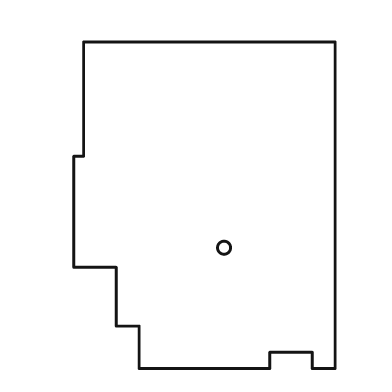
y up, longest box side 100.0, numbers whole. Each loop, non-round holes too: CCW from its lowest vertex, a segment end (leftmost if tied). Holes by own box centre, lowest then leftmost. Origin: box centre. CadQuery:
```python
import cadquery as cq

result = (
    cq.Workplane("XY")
    .moveTo(-20.0, -50.0)
    .lineTo(20.0, -50.0)
    .lineTo(20.0, -45.0)
    .lineTo(33.0, -45.0)
    .lineTo(33.0, -50.0)
    .lineTo(40.0, -50.0)
    .lineTo(40.0, 50.0)
    .lineTo(-37.0, 50.0)
    .lineTo(-37.0, 15.0)
    .lineTo(-40.0, 15.0)
    .lineTo(-40.0, -19.0)
    .lineTo(-27.0, -19.0)
    .lineTo(-27.0, -37.0)
    .lineTo(-20.0, -37.0)
    .close()
    .moveTo(6.0, -13.0)
    .circle(2.0)
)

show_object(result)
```